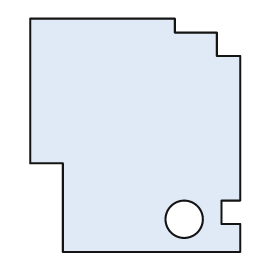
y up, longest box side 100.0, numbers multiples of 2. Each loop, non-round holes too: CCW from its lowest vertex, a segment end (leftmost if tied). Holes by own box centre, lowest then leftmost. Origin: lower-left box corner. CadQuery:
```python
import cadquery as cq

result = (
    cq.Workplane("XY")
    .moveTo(14.0, 0.0)
    .lineTo(90.0, 0.0)
    .lineTo(90.0, 12.0)
    .lineTo(82.0, 12.0)
    .lineTo(82.0, 22.0)
    .lineTo(90.0, 22.0)
    .lineTo(90.0, 84.0)
    .lineTo(80.0, 84.0)
    .lineTo(80.0, 94.0)
    .lineTo(62.0, 94.0)
    .lineTo(62.0, 100.0)
    .lineTo(0.0, 100.0)
    .lineTo(0.0, 38.0)
    .lineTo(14.0, 38.0)
    .close()
    .moveTo(66.0, 14.0)
    .circle(8.0)
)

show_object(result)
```